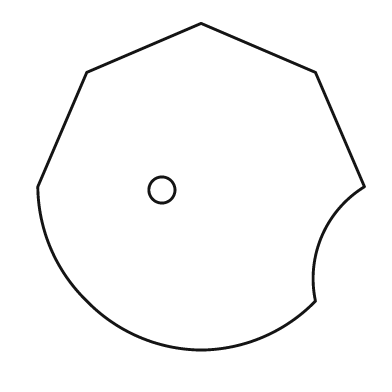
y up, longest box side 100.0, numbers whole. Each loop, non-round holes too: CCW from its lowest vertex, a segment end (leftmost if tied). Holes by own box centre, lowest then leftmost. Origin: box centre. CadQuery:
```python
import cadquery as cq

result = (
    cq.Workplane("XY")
    .moveTo(0.0, -50.0)
    .threePointArc((19.0, -46.0), (35.0, -35.0))
    .threePointArc((37.0, -15.0), (50.0, 0.0))
    .lineTo(35.0, 35.0)
    .lineTo(0.0, 50.0)
    .lineTo(-35.0, 35.0)
    .lineTo(-50.0, 0.0)
    .threePointArc((-46.0, -19.0), (-35.0, -35.0))
    .threePointArc((-19.0, -46.0), (0.0, -50.0))
    .close()
    .moveTo(-12.0, -1.0)
    .circle(4.0)
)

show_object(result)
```